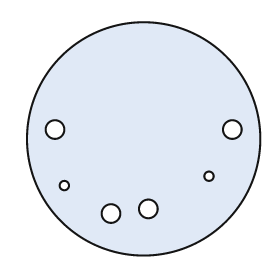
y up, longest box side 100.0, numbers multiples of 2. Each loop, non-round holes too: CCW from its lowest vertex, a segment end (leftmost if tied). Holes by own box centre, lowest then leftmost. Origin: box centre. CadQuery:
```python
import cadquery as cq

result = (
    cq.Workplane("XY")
    .moveTo(0.0, 0.0)
    .circle(50.0)
    .moveTo(-14.0, -32.0)
    .circle(4.0)
    .moveTo(2.0, -30.0)
    .circle(4.0)
    .moveTo(-34.0, -20.0)
    .circle(2.0)
    .moveTo(28.0, -16.0)
    .circle(2.0)
    .moveTo(-38.0, 4.0)
    .circle(4.0)
    .moveTo(38.0, 4.0)
    .circle(4.0)
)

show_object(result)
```